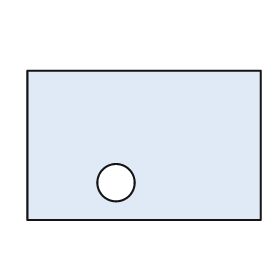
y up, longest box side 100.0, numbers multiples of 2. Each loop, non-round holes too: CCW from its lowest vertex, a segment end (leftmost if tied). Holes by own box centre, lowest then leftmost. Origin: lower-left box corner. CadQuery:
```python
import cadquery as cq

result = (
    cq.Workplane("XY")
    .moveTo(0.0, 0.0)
    .lineTo(100.0, 0.0)
    .lineTo(100.0, 64.0)
    .lineTo(0.0, 64.0)
    .close()
    .moveTo(38.0, 16.0)
    .circle(8.0)
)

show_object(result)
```